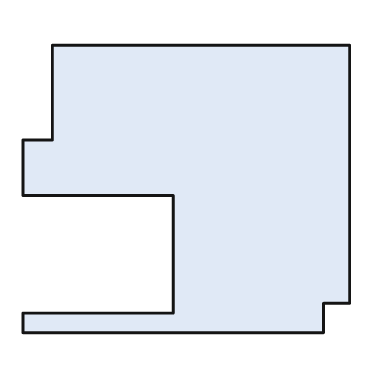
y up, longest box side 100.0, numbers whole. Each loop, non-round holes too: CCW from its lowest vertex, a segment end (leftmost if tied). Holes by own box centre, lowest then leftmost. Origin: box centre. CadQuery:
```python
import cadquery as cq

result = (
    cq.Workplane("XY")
    .moveTo(-50.0, -44.0)
    .lineTo(42.0, -44.0)
    .lineTo(42.0, -35.0)
    .lineTo(50.0, -35.0)
    .lineTo(50.0, 44.0)
    .lineTo(-41.0, 44.0)
    .lineTo(-41.0, 15.0)
    .lineTo(-50.0, 15.0)
    .lineTo(-50.0, -2.0)
    .lineTo(-4.0, -2.0)
    .lineTo(-4.0, -38.0)
    .lineTo(-50.0, -38.0)
    .close()
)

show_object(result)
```